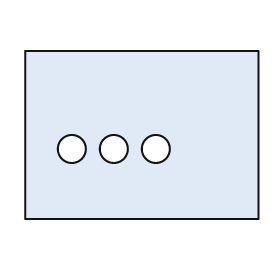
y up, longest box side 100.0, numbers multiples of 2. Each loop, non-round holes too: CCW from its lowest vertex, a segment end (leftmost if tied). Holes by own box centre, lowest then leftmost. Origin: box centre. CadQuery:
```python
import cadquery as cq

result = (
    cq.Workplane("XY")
    .moveTo(-50.0, -36.0)
    .lineTo(50.0, -36.0)
    .lineTo(50.0, 36.0)
    .lineTo(-50.0, 36.0)
    .close()
    .moveTo(-30.0, -6.0)
    .circle(6.0)
    .moveTo(-12.0, -6.0)
    .circle(6.0)
    .moveTo(6.0, -6.0)
    .circle(6.0)
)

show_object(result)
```